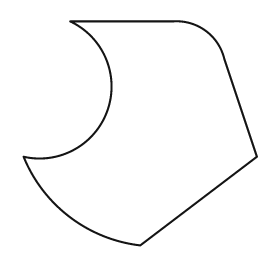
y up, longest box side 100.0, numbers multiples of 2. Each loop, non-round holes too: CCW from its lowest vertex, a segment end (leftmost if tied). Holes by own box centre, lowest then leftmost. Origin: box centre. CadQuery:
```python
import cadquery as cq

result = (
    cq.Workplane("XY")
    .moveTo(0.0, -48.0)
    .lineTo(50.0, -10.0)
    .lineTo(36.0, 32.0)
    .threePointArc((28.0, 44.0), (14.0, 48.0))
    .lineTo(-30.0, 48.0)
    .threePointArc((-14.0, 10.0), (-50.0, -10.0))
    .threePointArc((-30.0, -36.0), (0.0, -48.0))
    .close()
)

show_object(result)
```